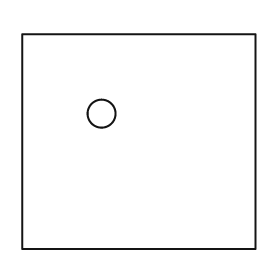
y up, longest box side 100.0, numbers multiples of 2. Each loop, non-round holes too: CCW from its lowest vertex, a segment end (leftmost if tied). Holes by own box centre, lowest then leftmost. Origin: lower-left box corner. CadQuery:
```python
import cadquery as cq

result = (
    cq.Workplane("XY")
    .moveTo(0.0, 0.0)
    .lineTo(100.0, 0.0)
    .lineTo(100.0, 92.0)
    .lineTo(0.0, 92.0)
    .close()
    .moveTo(34.0, 58.0)
    .circle(6.0)
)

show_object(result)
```